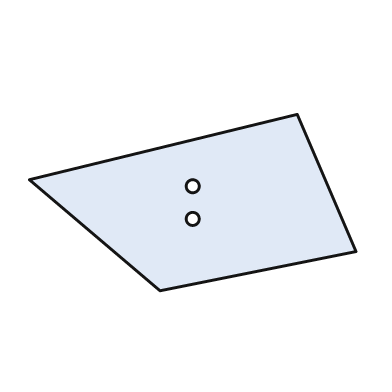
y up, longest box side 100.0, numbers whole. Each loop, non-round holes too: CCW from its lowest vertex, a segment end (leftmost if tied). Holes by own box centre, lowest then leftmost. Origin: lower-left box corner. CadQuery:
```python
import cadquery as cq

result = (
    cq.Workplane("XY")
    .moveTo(40.0, 0.0)
    .lineTo(100.0, 12.0)
    .lineTo(82.0, 54.0)
    .lineTo(0.0, 34.0)
    .close()
    .moveTo(50.0, 22.0)
    .circle(2.0)
    .moveTo(50.0, 32.0)
    .circle(2.0)
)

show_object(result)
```